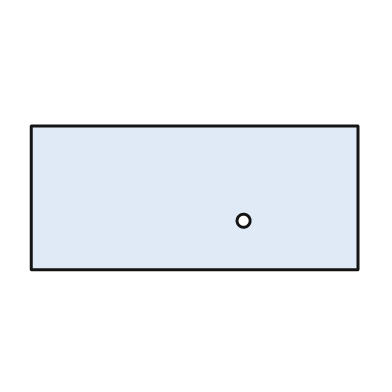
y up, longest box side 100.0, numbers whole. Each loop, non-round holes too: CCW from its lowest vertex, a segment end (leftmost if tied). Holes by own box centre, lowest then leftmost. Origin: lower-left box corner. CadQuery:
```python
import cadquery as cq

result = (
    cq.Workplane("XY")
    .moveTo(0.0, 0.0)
    .lineTo(100.0, 0.0)
    .lineTo(100.0, 44.0)
    .lineTo(0.0, 44.0)
    .close()
    .moveTo(65.0, 15.0)
    .circle(2.0)
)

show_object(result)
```